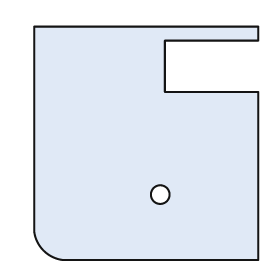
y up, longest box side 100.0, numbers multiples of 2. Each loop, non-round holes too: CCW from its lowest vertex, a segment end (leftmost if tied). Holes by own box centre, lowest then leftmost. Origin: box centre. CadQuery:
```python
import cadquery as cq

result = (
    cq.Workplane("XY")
    .moveTo(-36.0, -50.0)
    .lineTo(48.0, -50.0)
    .lineTo(48.0, 22.0)
    .lineTo(8.0, 22.0)
    .lineTo(8.0, 44.0)
    .lineTo(48.0, 44.0)
    .lineTo(48.0, 50.0)
    .lineTo(-48.0, 50.0)
    .lineTo(-48.0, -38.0)
    .threePointArc((-44.0, -46.0), (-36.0, -50.0))
    .close()
    .moveTo(6.0, -22.0)
    .circle(4.0)
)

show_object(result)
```